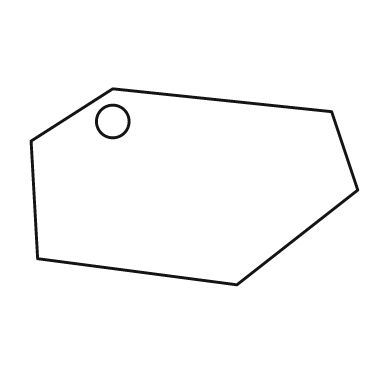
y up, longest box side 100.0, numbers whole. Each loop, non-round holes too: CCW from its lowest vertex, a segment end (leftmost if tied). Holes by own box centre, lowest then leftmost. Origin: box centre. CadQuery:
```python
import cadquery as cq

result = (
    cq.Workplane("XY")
    .moveTo(13.0, -30.0)
    .lineTo(50.0, -1.0)
    .lineTo(42.0, 23.0)
    .lineTo(-25.0, 30.0)
    .lineTo(-50.0, 14.0)
    .lineTo(-48.0, -22.0)
    .close()
    .moveTo(-25.0, 20.0)
    .circle(5.0)
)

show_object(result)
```